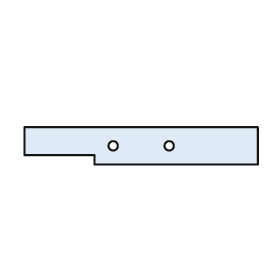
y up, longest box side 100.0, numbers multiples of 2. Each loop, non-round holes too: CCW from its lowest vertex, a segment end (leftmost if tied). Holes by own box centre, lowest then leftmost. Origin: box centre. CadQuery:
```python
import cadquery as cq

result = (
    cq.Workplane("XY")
    .moveTo(-20.0, -8.0)
    .lineTo(50.0, -8.0)
    .lineTo(50.0, 8.0)
    .lineTo(-50.0, 8.0)
    .lineTo(-50.0, -4.0)
    .lineTo(-20.0, -4.0)
    .close()
    .moveTo(-12.0, 0.0)
    .circle(2.0)
    .moveTo(12.0, 0.0)
    .circle(2.0)
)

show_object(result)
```